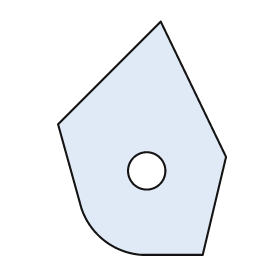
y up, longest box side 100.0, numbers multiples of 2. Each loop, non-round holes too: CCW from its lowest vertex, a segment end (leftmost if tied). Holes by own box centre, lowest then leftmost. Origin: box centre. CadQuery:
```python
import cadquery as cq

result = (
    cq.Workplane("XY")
    .moveTo(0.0, -50.0)
    .lineTo(26.0, -50.0)
    .lineTo(36.0, -8.0)
    .lineTo(8.0, 50.0)
    .lineTo(-36.0, 6.0)
    .lineTo(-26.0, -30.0)
    .threePointArc((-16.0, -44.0), (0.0, -50.0))
    .close()
    .moveTo(2.0, -14.0)
    .circle(8.0)
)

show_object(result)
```